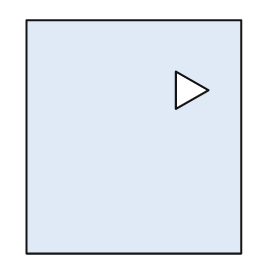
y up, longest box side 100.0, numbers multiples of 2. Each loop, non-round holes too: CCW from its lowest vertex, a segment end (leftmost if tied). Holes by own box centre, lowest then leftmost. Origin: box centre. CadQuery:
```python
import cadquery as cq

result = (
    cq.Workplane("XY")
    .moveTo(-46.0, -50.0)
    .lineTo(46.0, -50.0)
    .lineTo(46.0, 50.0)
    .lineTo(-46.0, 50.0)
    .close()
    .moveTo(18.0, 12.0)
    .lineTo(32.0, 20.0)
    .lineTo(18.0, 28.0)
    .close()
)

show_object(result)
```